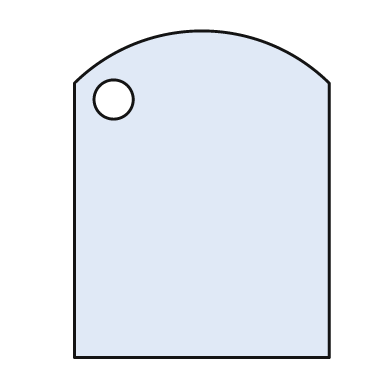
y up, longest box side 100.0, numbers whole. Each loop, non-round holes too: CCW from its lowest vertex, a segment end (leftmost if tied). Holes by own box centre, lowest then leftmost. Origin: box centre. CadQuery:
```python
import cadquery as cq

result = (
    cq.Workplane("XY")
    .moveTo(-39.0, -50.0)
    .lineTo(39.0, -50.0)
    .lineTo(39.0, 34.0)
    .threePointArc((0.0, 50.0), (-39.0, 34.0))
    .close()
    .moveTo(-27.0, 29.0)
    .circle(6.0)
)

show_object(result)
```